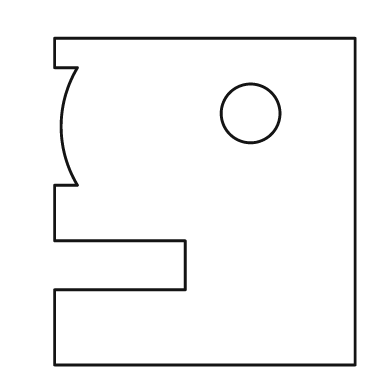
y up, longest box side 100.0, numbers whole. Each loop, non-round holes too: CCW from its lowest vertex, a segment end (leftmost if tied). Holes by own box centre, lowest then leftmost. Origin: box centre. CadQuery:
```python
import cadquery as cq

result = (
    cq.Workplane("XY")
    .moveTo(-46.0, -50.0)
    .lineTo(46.0, -50.0)
    .lineTo(46.0, 50.0)
    .lineTo(-46.0, 50.0)
    .lineTo(-46.0, 41.0)
    .lineTo(-39.0, 41.0)
    .threePointArc((-44.0, 23.0), (-39.0, 5.0))
    .lineTo(-46.0, 5.0)
    .lineTo(-46.0, -12.0)
    .lineTo(-6.0, -12.0)
    .lineTo(-6.0, -27.0)
    .lineTo(-46.0, -27.0)
    .close()
    .moveTo(14.0, 27.0)
    .circle(9.0)
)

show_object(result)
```